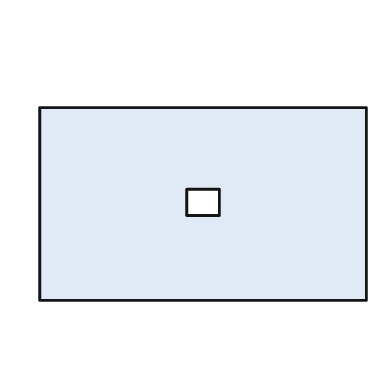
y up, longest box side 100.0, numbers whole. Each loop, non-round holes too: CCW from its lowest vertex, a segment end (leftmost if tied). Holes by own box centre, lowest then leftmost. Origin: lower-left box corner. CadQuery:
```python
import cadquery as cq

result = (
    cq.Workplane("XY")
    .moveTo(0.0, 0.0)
    .lineTo(100.0, 0.0)
    .lineTo(100.0, 59.0)
    .lineTo(0.0, 59.0)
    .close()
    .moveTo(45.0, 26.0)
    .lineTo(55.0, 26.0)
    .lineTo(55.0, 34.0)
    .lineTo(45.0, 34.0)
    .close()
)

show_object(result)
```